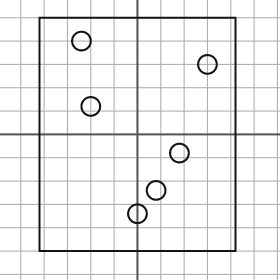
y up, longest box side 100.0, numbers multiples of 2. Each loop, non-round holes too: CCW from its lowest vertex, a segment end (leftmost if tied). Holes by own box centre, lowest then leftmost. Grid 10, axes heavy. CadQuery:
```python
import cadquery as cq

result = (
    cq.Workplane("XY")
    .moveTo(-42.0, -50.0)
    .lineTo(42.0, -50.0)
    .lineTo(42.0, 50.0)
    .lineTo(-42.0, 50.0)
    .close()
    .moveTo(0.0, -34.0)
    .circle(4.0)
    .moveTo(8.0, -24.0)
    .circle(4.0)
    .moveTo(18.0, -8.0)
    .circle(4.0)
    .moveTo(-20.0, 12.0)
    .circle(4.0)
    .moveTo(30.0, 30.0)
    .circle(4.0)
    .moveTo(-24.0, 40.0)
    .circle(4.0)
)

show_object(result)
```